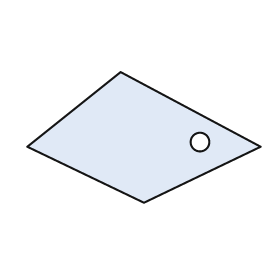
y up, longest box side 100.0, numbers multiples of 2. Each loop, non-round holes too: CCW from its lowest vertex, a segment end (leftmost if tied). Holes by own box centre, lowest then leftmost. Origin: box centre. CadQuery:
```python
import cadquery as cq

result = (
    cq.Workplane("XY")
    .moveTo(0.0, -28.0)
    .lineTo(50.0, -4.0)
    .lineTo(-10.0, 28.0)
    .lineTo(-50.0, -4.0)
    .close()
    .moveTo(24.0, -2.0)
    .circle(4.0)
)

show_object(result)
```